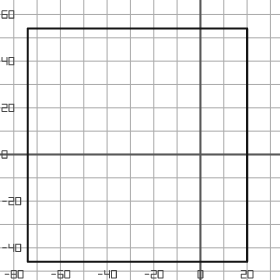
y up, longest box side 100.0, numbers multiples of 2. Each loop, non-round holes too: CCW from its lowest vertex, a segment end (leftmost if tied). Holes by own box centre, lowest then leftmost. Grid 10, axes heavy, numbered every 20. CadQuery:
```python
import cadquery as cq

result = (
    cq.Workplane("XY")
    .moveTo(-74.0, -46.0)
    .lineTo(20.0, -46.0)
    .lineTo(20.0, 54.0)
    .lineTo(-74.0, 54.0)
    .close()
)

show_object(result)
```